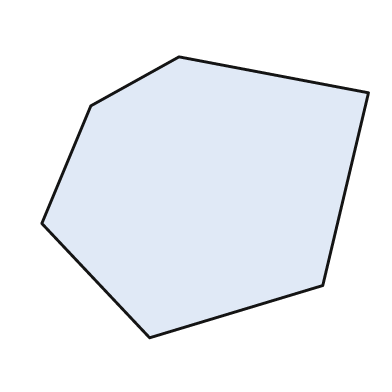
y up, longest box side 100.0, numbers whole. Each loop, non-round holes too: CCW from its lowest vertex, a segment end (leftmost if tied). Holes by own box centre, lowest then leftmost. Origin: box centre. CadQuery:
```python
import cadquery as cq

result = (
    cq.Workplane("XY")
    .moveTo(-17.0, -43.0)
    .lineTo(36.0, -27.0)
    .lineTo(50.0, 32.0)
    .lineTo(-8.0, 43.0)
    .lineTo(-35.0, 28.0)
    .lineTo(-50.0, -8.0)
    .close()
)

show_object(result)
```